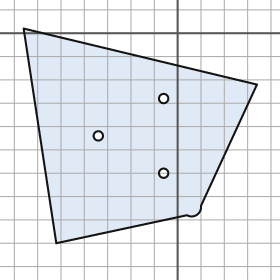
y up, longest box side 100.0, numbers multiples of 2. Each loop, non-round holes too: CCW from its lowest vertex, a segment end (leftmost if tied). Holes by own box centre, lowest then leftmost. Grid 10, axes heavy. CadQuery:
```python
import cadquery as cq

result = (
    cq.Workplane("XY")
    .moveTo(-52.0, -90.0)
    .lineTo(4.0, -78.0)
    .threePointArc((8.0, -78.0), (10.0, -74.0))
    .lineTo(34.0, -22.0)
    .lineTo(-66.0, 2.0)
    .close()
    .moveTo(-6.0, -60.0)
    .circle(2.0)
    .moveTo(-34.0, -44.0)
    .circle(2.0)
    .moveTo(-6.0, -28.0)
    .circle(2.0)
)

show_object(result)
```